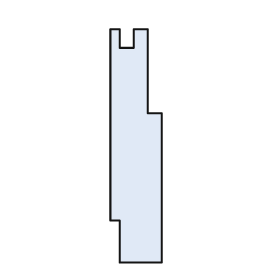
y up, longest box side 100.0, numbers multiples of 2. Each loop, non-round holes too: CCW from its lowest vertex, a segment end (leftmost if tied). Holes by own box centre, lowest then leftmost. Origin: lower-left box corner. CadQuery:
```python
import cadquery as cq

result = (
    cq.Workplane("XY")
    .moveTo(4.0, 0.0)
    .lineTo(22.0, 0.0)
    .lineTo(22.0, 64.0)
    .lineTo(16.0, 64.0)
    .lineTo(16.0, 100.0)
    .lineTo(10.0, 100.0)
    .lineTo(10.0, 92.0)
    .lineTo(4.0, 92.0)
    .lineTo(4.0, 100.0)
    .lineTo(0.0, 100.0)
    .lineTo(0.0, 18.0)
    .lineTo(4.0, 18.0)
    .close()
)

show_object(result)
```